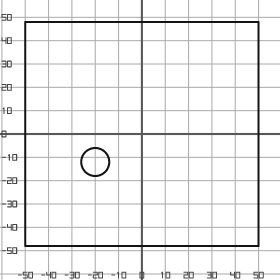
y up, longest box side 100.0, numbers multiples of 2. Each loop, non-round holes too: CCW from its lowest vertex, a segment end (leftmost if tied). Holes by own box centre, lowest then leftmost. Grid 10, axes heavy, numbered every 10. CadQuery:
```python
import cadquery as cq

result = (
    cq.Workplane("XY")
    .moveTo(-50.0, -48.0)
    .lineTo(50.0, -48.0)
    .lineTo(50.0, 48.0)
    .lineTo(-50.0, 48.0)
    .close()
    .moveTo(-20.0, -12.0)
    .circle(6.0)
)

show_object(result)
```